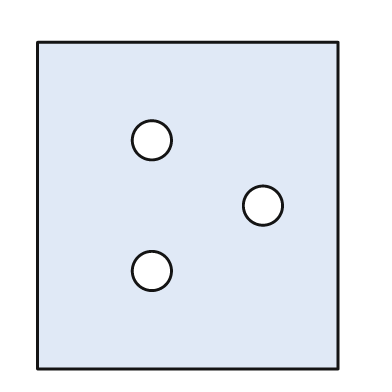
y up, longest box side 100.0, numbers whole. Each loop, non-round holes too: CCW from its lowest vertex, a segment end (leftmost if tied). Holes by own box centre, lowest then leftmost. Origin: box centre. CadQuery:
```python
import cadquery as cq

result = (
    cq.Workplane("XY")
    .moveTo(-46.0, -50.0)
    .lineTo(46.0, -50.0)
    .lineTo(46.0, 50.0)
    .lineTo(-46.0, 50.0)
    .close()
    .moveTo(-11.0, -20.0)
    .circle(6.0)
    .moveTo(23.0, 0.0)
    .circle(6.0)
    .moveTo(-11.0, 20.0)
    .circle(6.0)
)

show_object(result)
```